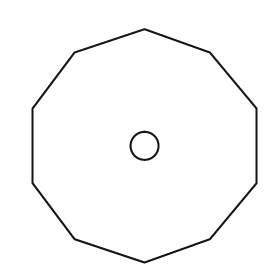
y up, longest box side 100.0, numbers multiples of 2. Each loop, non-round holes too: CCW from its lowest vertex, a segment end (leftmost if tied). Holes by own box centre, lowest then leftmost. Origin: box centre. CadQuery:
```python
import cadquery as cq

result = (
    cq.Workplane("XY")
    .moveTo(0.0, -50.0)
    .lineTo(28.0, -40.0)
    .lineTo(48.0, -16.0)
    .lineTo(48.0, 16.0)
    .lineTo(28.0, 40.0)
    .lineTo(0.0, 50.0)
    .lineTo(-30.0, 40.0)
    .lineTo(-48.0, 16.0)
    .lineTo(-48.0, -16.0)
    .lineTo(-30.0, -40.0)
    .close()
    .moveTo(0.0, 0.0)
    .circle(6.0)
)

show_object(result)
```